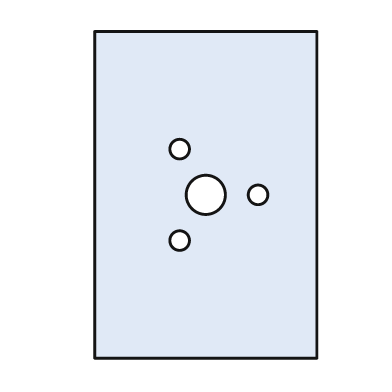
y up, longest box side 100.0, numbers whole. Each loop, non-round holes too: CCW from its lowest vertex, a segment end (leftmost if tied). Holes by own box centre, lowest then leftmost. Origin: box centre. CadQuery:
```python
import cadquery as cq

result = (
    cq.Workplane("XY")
    .moveTo(-34.0, -50.0)
    .lineTo(34.0, -50.0)
    .lineTo(34.0, 50.0)
    .lineTo(-34.0, 50.0)
    .close()
    .moveTo(-8.0, -14.0)
    .circle(3.0)
    .moveTo(0.0, 0.0)
    .circle(6.0)
    .moveTo(16.0, 0.0)
    .circle(3.0)
    .moveTo(-8.0, 14.0)
    .circle(3.0)
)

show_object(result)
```